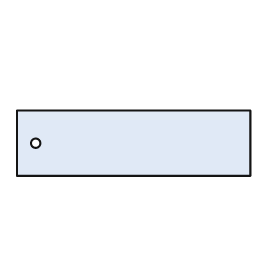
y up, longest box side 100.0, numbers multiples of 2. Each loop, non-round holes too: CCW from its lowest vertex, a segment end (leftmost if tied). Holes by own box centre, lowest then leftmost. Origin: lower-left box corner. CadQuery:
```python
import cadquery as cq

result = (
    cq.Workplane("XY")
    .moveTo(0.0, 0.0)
    .lineTo(100.0, 0.0)
    .lineTo(100.0, 28.0)
    .lineTo(0.0, 28.0)
    .close()
    .moveTo(8.0, 14.0)
    .circle(2.0)
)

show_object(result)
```